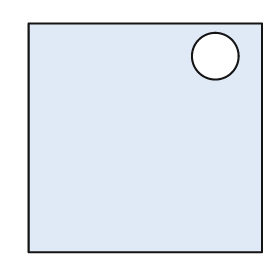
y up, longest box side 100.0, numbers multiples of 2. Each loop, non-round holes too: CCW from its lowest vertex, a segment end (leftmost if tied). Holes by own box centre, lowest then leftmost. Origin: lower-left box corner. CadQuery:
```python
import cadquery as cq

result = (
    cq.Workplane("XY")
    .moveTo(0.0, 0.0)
    .lineTo(100.0, 0.0)
    .lineTo(100.0, 98.0)
    .lineTo(0.0, 98.0)
    .close()
    .moveTo(80.0, 84.0)
    .circle(10.0)
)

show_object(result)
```